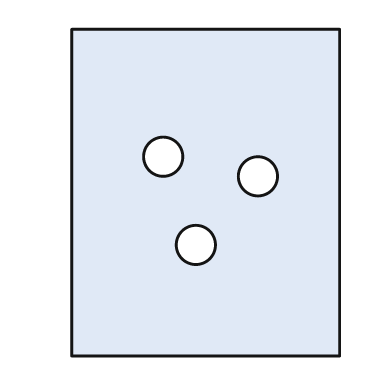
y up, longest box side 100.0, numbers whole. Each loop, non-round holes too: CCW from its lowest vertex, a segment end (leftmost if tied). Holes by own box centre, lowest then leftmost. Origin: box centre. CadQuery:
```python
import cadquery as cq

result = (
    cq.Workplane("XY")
    .moveTo(-41.0, -50.0)
    .lineTo(41.0, -50.0)
    .lineTo(41.0, 50.0)
    .lineTo(-41.0, 50.0)
    .close()
    .moveTo(-3.0, -16.0)
    .circle(6.0)
    .moveTo(16.0, 5.0)
    .circle(6.0)
    .moveTo(-13.0, 11.0)
    .circle(6.0)
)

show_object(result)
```